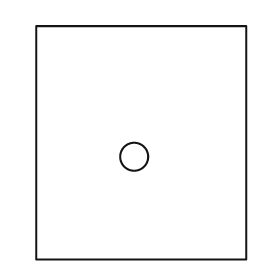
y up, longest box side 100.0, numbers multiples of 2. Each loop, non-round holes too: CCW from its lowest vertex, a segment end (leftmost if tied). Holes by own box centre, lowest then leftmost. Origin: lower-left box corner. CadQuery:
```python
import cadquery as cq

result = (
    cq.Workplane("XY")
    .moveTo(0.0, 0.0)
    .lineTo(90.0, 0.0)
    .lineTo(90.0, 100.0)
    .lineTo(0.0, 100.0)
    .close()
    .moveTo(42.0, 44.0)
    .circle(6.0)
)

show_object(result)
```